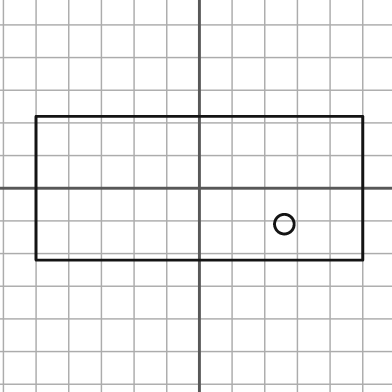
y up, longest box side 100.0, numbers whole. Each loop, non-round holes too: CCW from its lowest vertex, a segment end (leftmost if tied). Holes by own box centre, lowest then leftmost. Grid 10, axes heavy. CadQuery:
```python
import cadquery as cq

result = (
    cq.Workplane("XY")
    .moveTo(-50.0, -22.0)
    .lineTo(50.0, -22.0)
    .lineTo(50.0, 22.0)
    .lineTo(-50.0, 22.0)
    .close()
    .moveTo(26.0, -11.0)
    .circle(3.0)
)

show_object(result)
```